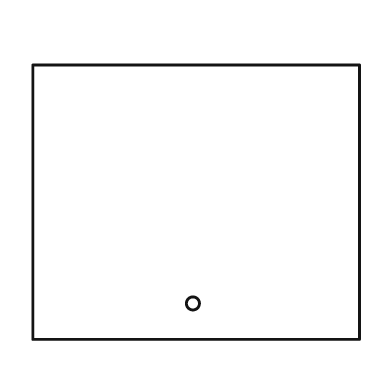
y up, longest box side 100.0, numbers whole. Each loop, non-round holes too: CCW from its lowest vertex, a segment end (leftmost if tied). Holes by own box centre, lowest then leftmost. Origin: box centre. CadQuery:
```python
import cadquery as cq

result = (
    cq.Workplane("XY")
    .moveTo(-50.0, -42.0)
    .lineTo(50.0, -42.0)
    .lineTo(50.0, 42.0)
    .lineTo(-50.0, 42.0)
    .close()
    .moveTo(-1.0, -31.0)
    .circle(2.0)
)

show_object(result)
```